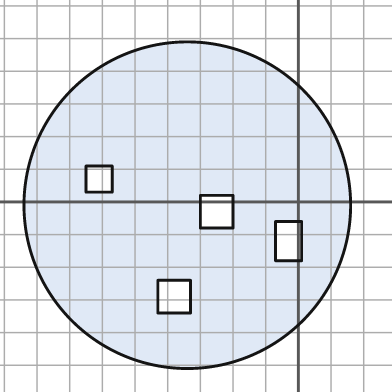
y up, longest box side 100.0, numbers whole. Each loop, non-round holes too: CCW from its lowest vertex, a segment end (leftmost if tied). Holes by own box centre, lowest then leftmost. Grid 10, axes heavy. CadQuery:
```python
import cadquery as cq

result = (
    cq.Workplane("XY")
    .moveTo(-34.0, -1.0)
    .circle(50.0)
    .moveTo(-43.0, -34.0)
    .lineTo(-33.0, -34.0)
    .lineTo(-33.0, -24.0)
    .lineTo(-43.0, -24.0)
    .close()
    .moveTo(-7.0, -18.0)
    .lineTo(1.0, -18.0)
    .lineTo(1.0, -6.0)
    .lineTo(-7.0, -6.0)
    .close()
    .moveTo(-30.0, -8.0)
    .lineTo(-20.0, -8.0)
    .lineTo(-20.0, 2.0)
    .lineTo(-30.0, 2.0)
    .close()
    .moveTo(-65.0, 3.0)
    .lineTo(-57.0, 3.0)
    .lineTo(-57.0, 11.0)
    .lineTo(-65.0, 11.0)
    .close()
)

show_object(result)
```